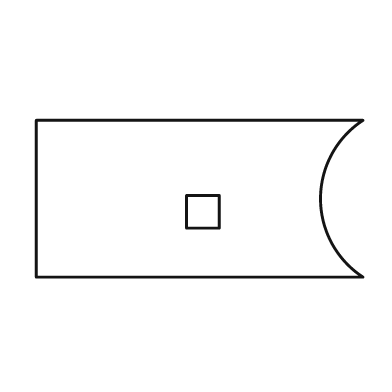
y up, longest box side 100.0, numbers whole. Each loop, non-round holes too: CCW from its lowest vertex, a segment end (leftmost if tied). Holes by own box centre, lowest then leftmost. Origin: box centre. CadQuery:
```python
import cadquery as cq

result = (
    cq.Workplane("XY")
    .moveTo(-50.0, -24.0)
    .lineTo(50.0, -24.0)
    .threePointArc((37.0, 0.0), (50.0, 24.0))
    .lineTo(-50.0, 24.0)
    .close()
    .moveTo(-4.0, -9.0)
    .lineTo(6.0, -9.0)
    .lineTo(6.0, 1.0)
    .lineTo(-4.0, 1.0)
    .close()
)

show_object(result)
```